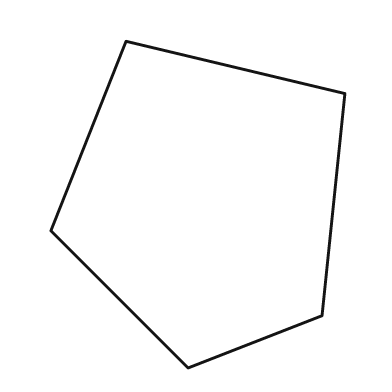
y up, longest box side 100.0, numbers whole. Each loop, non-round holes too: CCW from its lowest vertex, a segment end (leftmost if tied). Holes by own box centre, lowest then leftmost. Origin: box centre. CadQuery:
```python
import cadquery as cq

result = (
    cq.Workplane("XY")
    .moveTo(-3.0, -50.0)
    .lineTo(38.0, -34.0)
    .lineTo(45.0, 34.0)
    .lineTo(-22.0, 50.0)
    .lineTo(-45.0, -8.0)
    .close()
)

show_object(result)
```